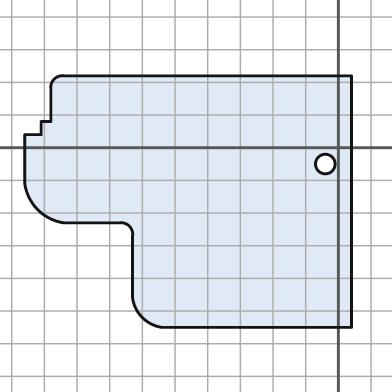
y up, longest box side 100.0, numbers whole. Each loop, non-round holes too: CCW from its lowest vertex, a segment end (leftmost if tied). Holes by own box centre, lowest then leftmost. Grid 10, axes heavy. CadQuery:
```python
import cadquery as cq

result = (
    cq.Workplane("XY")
    .moveTo(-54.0, -55.0)
    .lineTo(4.0, -55.0)
    .lineTo(4.0, 22.0)
    .lineTo(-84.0, 22.0)
    .threePointArc((-87.0, 21.0), (-88.0, 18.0))
    .lineTo(-88.0, 8.0)
    .lineTo(-91.0, 8.0)
    .lineTo(-91.0, 4.0)
    .lineTo(-96.0, 4.0)
    .lineTo(-96.0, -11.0)
    .threePointArc((-92.0, -19.0), (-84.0, -23.0))
    .lineTo(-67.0, -23.0)
    .threePointArc((-64.0, -24.0), (-63.0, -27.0))
    .lineTo(-63.0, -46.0)
    .threePointArc((-60.0, -52.0), (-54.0, -55.0))
    .close()
    .moveTo(-4.0, -5.0)
    .circle(3.0)
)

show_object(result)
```